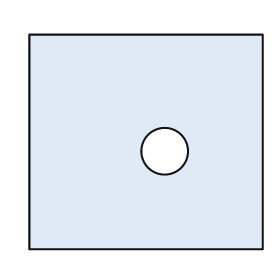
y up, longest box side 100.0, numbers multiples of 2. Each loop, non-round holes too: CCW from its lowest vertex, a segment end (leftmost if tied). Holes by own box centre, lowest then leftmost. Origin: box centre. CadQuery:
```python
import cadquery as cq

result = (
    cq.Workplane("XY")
    .moveTo(-50.0, -46.0)
    .lineTo(50.0, -46.0)
    .lineTo(50.0, 46.0)
    .lineTo(-50.0, 46.0)
    .close()
    .moveTo(8.0, -4.0)
    .circle(10.0)
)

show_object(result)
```